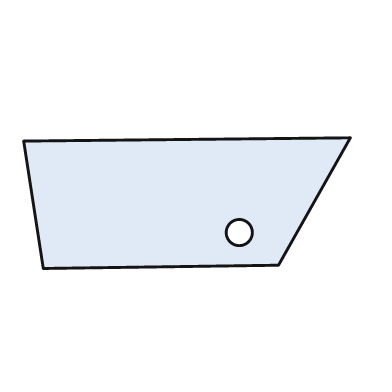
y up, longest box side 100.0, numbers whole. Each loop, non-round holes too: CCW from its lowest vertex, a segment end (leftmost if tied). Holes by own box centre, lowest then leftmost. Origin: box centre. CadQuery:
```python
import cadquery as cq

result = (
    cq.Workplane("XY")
    .moveTo(-44.0, -20.0)
    .lineTo(28.0, -19.0)
    .lineTo(50.0, 20.0)
    .lineTo(-50.0, 19.0)
    .close()
    .moveTo(16.0, -9.0)
    .circle(4.0)
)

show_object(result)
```